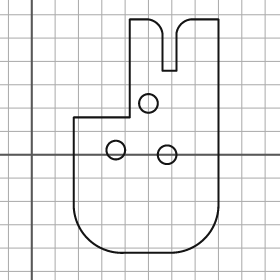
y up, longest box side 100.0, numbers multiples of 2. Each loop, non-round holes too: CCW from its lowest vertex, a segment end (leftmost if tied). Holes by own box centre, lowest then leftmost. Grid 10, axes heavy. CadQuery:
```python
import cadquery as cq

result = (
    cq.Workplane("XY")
    .moveTo(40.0, -42.0)
    .lineTo(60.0, -42.0)
    .threePointArc((74.0, -36.0), (80.0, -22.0))
    .lineTo(80.0, 58.0)
    .lineTo(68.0, 58.0)
    .threePointArc((64.0, 56.0), (62.0, 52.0))
    .lineTo(62.0, 36.0)
    .lineTo(56.0, 36.0)
    .lineTo(56.0, 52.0)
    .threePointArc((54.0, 56.0), (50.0, 58.0))
    .lineTo(42.0, 58.0)
    .lineTo(42.0, 16.0)
    .lineTo(18.0, 16.0)
    .lineTo(18.0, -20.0)
    .threePointArc((24.0, -36.0), (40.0, -42.0))
    .close()
    .moveTo(58.0, 0.0)
    .circle(4.0)
    .moveTo(36.0, 2.0)
    .circle(4.0)
    .moveTo(50.0, 22.0)
    .circle(4.0)
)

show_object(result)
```